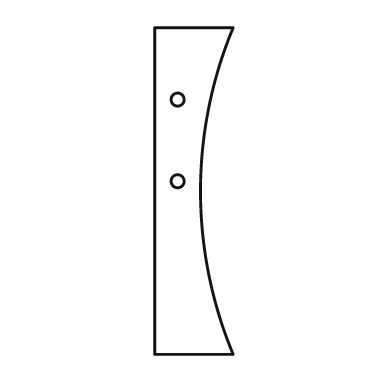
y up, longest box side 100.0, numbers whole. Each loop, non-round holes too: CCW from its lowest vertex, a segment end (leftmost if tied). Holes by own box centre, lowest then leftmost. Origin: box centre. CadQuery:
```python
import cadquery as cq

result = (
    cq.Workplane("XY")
    .moveTo(-12.0, -50.0)
    .lineTo(12.0, -50.0)
    .threePointArc((2.0, 0.0), (12.0, 50.0))
    .lineTo(-12.0, 50.0)
    .close()
    .moveTo(-5.0, 3.0)
    .circle(2.0)
    .moveTo(-5.0, 28.0)
    .circle(2.0)
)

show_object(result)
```